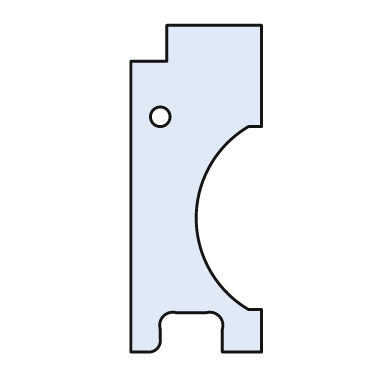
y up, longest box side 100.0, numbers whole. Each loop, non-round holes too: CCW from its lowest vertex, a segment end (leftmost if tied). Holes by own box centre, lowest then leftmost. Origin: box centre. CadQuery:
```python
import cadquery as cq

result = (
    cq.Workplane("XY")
    .moveTo(-20.0, -50.0)
    .lineTo(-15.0, -50.0)
    .threePointArc((-12.0, -49.0), (-11.0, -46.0))
    .lineTo(-11.0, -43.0)
    .threePointArc((-10.0, -39.0), (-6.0, -38.0))
    .lineTo(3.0, -38.0)
    .threePointArc((7.0, -39.0), (8.0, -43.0))
    .lineTo(8.0, -50.0)
    .lineTo(20.0, -50.0)
    .lineTo(20.0, -37.0)
    .lineTo(16.0, -37.0)
    .threePointArc((0.0, -9.0), (16.0, 19.0))
    .lineTo(20.0, 19.0)
    .lineTo(20.0, 50.0)
    .lineTo(-9.0, 50.0)
    .lineTo(-9.0, 39.0)
    .lineTo(-20.0, 39.0)
    .close()
    .moveTo(-11.0, 22.0)
    .circle(3.0)
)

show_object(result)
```